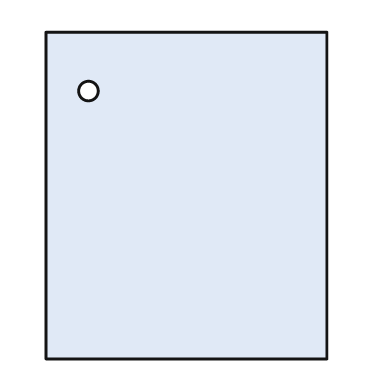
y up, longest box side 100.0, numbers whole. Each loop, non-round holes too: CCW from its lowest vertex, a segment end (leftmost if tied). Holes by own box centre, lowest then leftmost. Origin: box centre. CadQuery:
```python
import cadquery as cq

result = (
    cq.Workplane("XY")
    .moveTo(-43.0, -50.0)
    .lineTo(43.0, -50.0)
    .lineTo(43.0, 50.0)
    .lineTo(-43.0, 50.0)
    .close()
    .moveTo(-30.0, 32.0)
    .circle(3.0)
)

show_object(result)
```